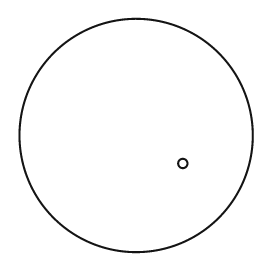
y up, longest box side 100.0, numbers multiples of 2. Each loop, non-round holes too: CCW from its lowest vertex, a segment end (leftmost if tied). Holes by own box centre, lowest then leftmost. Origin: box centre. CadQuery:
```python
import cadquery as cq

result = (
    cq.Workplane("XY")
    .moveTo(0.0, 0.0)
    .circle(50.0)
    .moveTo(20.0, -12.0)
    .circle(2.0)
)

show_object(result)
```